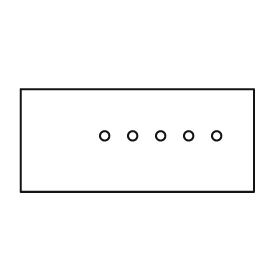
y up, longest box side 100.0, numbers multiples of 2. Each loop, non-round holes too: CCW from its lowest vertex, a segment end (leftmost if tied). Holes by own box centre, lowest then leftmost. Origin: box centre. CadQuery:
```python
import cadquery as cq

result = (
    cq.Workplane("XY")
    .moveTo(-50.0, -22.0)
    .lineTo(50.0, -22.0)
    .lineTo(50.0, 22.0)
    .lineTo(-50.0, 22.0)
    .close()
    .moveTo(-14.0, 2.0)
    .circle(2.0)
    .moveTo(-2.0, 2.0)
    .circle(2.0)
    .moveTo(10.0, 2.0)
    .circle(2.0)
    .moveTo(22.0, 2.0)
    .circle(2.0)
    .moveTo(34.0, 2.0)
    .circle(2.0)
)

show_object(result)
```